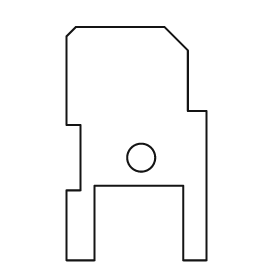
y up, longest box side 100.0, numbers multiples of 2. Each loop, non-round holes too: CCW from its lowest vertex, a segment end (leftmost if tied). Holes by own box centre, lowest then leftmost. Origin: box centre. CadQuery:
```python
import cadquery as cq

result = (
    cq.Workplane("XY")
    .moveTo(-30.0, -50.0)
    .lineTo(-18.0, -50.0)
    .lineTo(-18.0, -18.0)
    .lineTo(20.0, -18.0)
    .lineTo(20.0, -50.0)
    .lineTo(30.0, -50.0)
    .lineTo(30.0, 14.0)
    .lineTo(22.0, 14.0)
    .lineTo(22.0, 40.0)
    .lineTo(12.0, 50.0)
    .lineTo(-26.0, 50.0)
    .lineTo(-30.0, 46.0)
    .lineTo(-30.0, 8.0)
    .lineTo(-24.0, 8.0)
    .lineTo(-24.0, -20.0)
    .lineTo(-30.0, -20.0)
    .close()
    .moveTo(2.0, -6.0)
    .circle(6.0)
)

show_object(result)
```